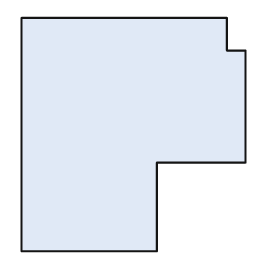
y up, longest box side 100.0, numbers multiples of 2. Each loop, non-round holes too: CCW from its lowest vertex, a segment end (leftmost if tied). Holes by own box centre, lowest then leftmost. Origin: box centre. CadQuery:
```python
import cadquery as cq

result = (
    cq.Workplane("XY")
    .moveTo(-48.0, -50.0)
    .lineTo(10.0, -50.0)
    .lineTo(10.0, -12.0)
    .lineTo(48.0, -12.0)
    .lineTo(48.0, 36.0)
    .lineTo(40.0, 36.0)
    .lineTo(40.0, 50.0)
    .lineTo(-48.0, 50.0)
    .close()
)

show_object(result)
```